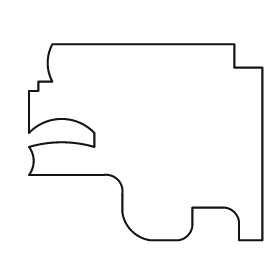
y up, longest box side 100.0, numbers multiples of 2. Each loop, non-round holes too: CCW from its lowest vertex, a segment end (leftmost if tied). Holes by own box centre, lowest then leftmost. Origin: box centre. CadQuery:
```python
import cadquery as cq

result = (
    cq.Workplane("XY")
    .moveTo(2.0, -42.0)
    .lineTo(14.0, -42.0)
    .threePointArc((18.0, -40.0), (20.0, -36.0))
    .lineTo(20.0, -28.0)
    .lineTo(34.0, -28.0)
    .threePointArc((38.0, -30.0), (40.0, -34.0))
    .lineTo(40.0, -42.0)
    .lineTo(50.0, -42.0)
    .lineTo(50.0, 32.0)
    .lineTo(38.0, 32.0)
    .lineTo(38.0, 42.0)
    .lineTo(-40.0, 42.0)
    .threePointArc((-42.0, 34.0), (-40.0, 26.0))
    .lineTo(-46.0, 26.0)
    .lineTo(-46.0, 22.0)
    .lineTo(-50.0, 22.0)
    .lineTo(-50.0, 4.0)
    .threePointArc((-36.0, 10.0), (-22.0, 4.0))
    .lineTo(-22.0, -2.0)
    .threePointArc((-36.0, 0.0), (-50.0, -2.0))
    .threePointArc((-48.0, -8.0), (-50.0, -14.0))
    .lineTo(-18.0, -14.0)
    .threePointArc((-12.0, -16.0), (-10.0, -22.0))
    .lineTo(-10.0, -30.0)
    .threePointArc((-6.0, -38.0), (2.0, -42.0))
    .close()
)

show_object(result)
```